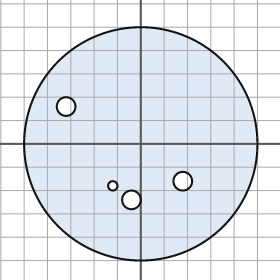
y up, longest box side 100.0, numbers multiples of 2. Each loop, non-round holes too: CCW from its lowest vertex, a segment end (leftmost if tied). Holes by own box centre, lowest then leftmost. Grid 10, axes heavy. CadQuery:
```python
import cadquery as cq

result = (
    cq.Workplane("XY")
    .moveTo(0.0, 0.0)
    .circle(50.0)
    .moveTo(-4.0, -24.0)
    .circle(4.0)
    .moveTo(-12.0, -18.0)
    .circle(2.0)
    .moveTo(18.0, -16.0)
    .circle(4.0)
    .moveTo(-32.0, 16.0)
    .circle(4.0)
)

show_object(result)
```